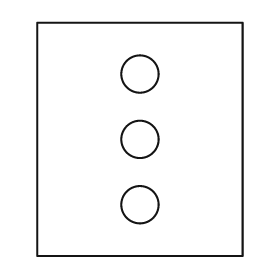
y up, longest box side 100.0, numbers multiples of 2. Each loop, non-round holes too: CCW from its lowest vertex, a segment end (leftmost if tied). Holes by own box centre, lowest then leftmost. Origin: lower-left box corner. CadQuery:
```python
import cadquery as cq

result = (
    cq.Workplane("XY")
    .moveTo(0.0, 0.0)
    .lineTo(88.0, 0.0)
    .lineTo(88.0, 100.0)
    .lineTo(0.0, 100.0)
    .close()
    .moveTo(44.0, 22.0)
    .circle(8.0)
    .moveTo(44.0, 50.0)
    .circle(8.0)
    .moveTo(44.0, 78.0)
    .circle(8.0)
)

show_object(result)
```